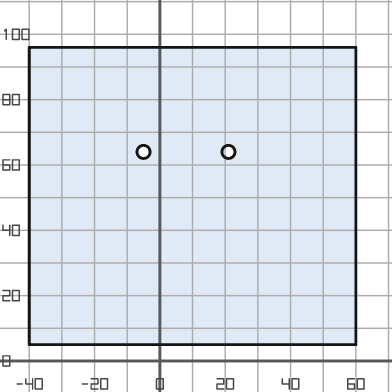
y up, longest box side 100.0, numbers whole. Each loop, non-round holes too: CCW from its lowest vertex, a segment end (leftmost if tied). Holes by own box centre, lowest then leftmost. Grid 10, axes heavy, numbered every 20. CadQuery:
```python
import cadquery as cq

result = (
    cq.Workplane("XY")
    .moveTo(-40.0, 5.0)
    .lineTo(60.0, 5.0)
    .lineTo(60.0, 96.0)
    .lineTo(-40.0, 96.0)
    .close()
    .moveTo(-5.0, 64.0)
    .circle(2.0)
    .moveTo(21.0, 64.0)
    .circle(2.0)
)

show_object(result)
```